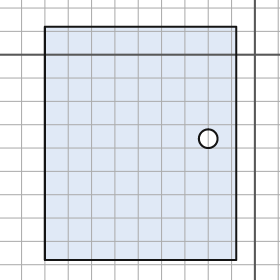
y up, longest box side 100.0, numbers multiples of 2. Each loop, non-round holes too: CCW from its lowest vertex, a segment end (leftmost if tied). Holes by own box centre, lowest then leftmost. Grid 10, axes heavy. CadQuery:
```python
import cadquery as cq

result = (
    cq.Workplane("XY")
    .moveTo(-90.0, -88.0)
    .lineTo(-8.0, -88.0)
    .lineTo(-8.0, 12.0)
    .lineTo(-90.0, 12.0)
    .close()
    .moveTo(-20.0, -36.0)
    .circle(4.0)
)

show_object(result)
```